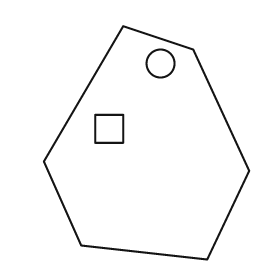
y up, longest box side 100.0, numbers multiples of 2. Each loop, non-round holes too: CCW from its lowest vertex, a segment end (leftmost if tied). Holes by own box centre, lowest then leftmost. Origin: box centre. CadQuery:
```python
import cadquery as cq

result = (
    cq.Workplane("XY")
    .moveTo(26.0, -50.0)
    .lineTo(44.0, -12.0)
    .lineTo(20.0, 40.0)
    .lineTo(-10.0, 50.0)
    .lineTo(-44.0, -8.0)
    .lineTo(-28.0, -44.0)
    .close()
    .moveTo(-22.0, 0.0)
    .lineTo(-10.0, 0.0)
    .lineTo(-10.0, 12.0)
    .lineTo(-22.0, 12.0)
    .close()
    .moveTo(6.0, 34.0)
    .circle(6.0)
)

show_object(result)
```